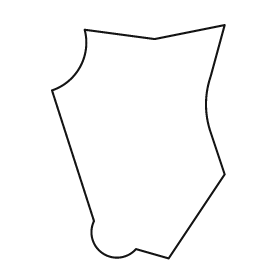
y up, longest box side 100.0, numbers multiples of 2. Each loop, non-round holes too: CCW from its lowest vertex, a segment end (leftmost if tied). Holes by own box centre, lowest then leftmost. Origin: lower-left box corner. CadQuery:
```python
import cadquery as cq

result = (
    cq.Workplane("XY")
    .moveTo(50.0, 0.0)
    .lineTo(74.0, 36.0)
    .lineTo(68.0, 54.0)
    .threePointArc((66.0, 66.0), (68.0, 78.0))
    .lineTo(74.0, 100.0)
    .lineTo(44.0, 94.0)
    .lineTo(14.0, 98.0)
    .threePointArc((12.0, 82.0), (0.0, 72.0))
    .lineTo(18.0, 16.0)
    .threePointArc((22.0, 2.0), (36.0, 4.0))
    .close()
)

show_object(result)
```